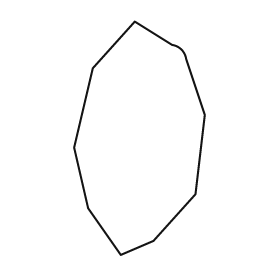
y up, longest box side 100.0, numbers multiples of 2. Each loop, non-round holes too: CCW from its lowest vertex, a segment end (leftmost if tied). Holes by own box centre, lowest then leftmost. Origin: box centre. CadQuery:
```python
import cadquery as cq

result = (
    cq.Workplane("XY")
    .moveTo(-8.0, -50.0)
    .lineTo(6.0, -44.0)
    .lineTo(24.0, -24.0)
    .lineTo(28.0, 10.0)
    .lineTo(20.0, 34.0)
    .threePointArc((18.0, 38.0), (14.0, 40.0))
    .lineTo(-2.0, 50.0)
    .lineTo(-20.0, 30.0)
    .lineTo(-28.0, -4.0)
    .lineTo(-22.0, -30.0)
    .close()
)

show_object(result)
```